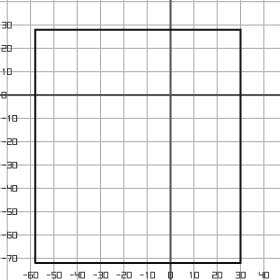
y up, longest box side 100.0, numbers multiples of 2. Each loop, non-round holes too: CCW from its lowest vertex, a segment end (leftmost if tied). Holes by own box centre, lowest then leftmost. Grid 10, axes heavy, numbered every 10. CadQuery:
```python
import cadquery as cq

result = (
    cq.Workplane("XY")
    .moveTo(-58.0, -72.0)
    .lineTo(30.0, -72.0)
    .lineTo(30.0, 28.0)
    .lineTo(-58.0, 28.0)
    .close()
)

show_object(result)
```